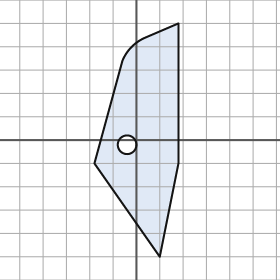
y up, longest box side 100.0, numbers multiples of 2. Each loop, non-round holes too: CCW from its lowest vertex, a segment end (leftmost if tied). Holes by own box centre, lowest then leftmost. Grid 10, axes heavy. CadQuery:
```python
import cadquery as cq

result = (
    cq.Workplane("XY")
    .moveTo(10.0, -50.0)
    .lineTo(18.0, -10.0)
    .lineTo(18.0, 50.0)
    .lineTo(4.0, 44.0)
    .threePointArc((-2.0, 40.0), (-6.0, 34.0))
    .lineTo(-18.0, -10.0)
    .close()
    .moveTo(-4.0, -2.0)
    .circle(4.0)
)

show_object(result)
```